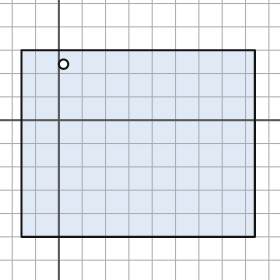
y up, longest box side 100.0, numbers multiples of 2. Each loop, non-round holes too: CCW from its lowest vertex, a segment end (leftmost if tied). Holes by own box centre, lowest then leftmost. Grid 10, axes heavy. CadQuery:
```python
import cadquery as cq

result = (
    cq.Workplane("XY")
    .moveTo(-16.0, -50.0)
    .lineTo(84.0, -50.0)
    .lineTo(84.0, 30.0)
    .lineTo(-16.0, 30.0)
    .close()
    .moveTo(2.0, 24.0)
    .circle(2.0)
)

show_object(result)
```